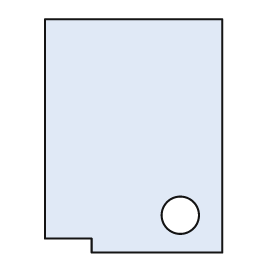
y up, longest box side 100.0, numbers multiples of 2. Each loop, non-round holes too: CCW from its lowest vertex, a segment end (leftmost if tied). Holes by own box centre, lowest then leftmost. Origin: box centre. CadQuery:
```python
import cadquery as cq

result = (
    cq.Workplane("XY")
    .moveTo(-18.0, -50.0)
    .lineTo(38.0, -50.0)
    .lineTo(38.0, 50.0)
    .lineTo(-38.0, 50.0)
    .lineTo(-38.0, -44.0)
    .lineTo(-18.0, -44.0)
    .close()
    .moveTo(20.0, -34.0)
    .circle(8.0)
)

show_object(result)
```